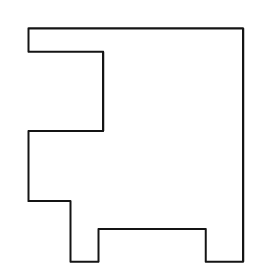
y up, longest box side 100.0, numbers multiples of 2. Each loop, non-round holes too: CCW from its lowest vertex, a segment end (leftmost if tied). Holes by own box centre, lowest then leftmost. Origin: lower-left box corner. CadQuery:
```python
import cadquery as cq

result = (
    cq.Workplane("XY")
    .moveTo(18.0, 0.0)
    .lineTo(30.0, 0.0)
    .lineTo(30.0, 14.0)
    .lineTo(76.0, 14.0)
    .lineTo(76.0, 0.0)
    .lineTo(92.0, 0.0)
    .lineTo(92.0, 100.0)
    .lineTo(0.0, 100.0)
    .lineTo(0.0, 90.0)
    .lineTo(32.0, 90.0)
    .lineTo(32.0, 56.0)
    .lineTo(0.0, 56.0)
    .lineTo(0.0, 26.0)
    .lineTo(18.0, 26.0)
    .close()
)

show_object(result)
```